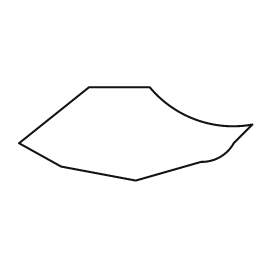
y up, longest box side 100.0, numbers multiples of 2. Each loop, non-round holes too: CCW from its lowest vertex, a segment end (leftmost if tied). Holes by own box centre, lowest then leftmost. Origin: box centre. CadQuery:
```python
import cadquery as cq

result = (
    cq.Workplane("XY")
    .moveTo(0.0, -20.0)
    .lineTo(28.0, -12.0)
    .threePointArc((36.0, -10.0), (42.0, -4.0))
    .lineTo(50.0, 4.0)
    .threePointArc((26.0, 6.0), (6.0, 20.0))
    .lineTo(-20.0, 20.0)
    .lineTo(-50.0, -4.0)
    .lineTo(-32.0, -14.0)
    .close()
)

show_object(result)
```